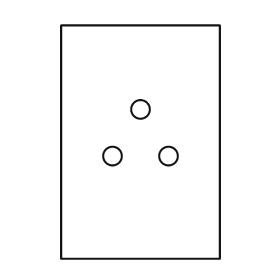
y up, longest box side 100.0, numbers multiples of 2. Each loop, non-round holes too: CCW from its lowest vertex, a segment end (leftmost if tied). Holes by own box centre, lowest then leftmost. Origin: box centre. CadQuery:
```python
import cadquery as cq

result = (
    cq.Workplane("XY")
    .moveTo(-34.0, -50.0)
    .lineTo(34.0, -50.0)
    .lineTo(34.0, 50.0)
    .lineTo(-34.0, 50.0)
    .close()
    .moveTo(-12.0, -6.0)
    .circle(4.0)
    .moveTo(12.0, -6.0)
    .circle(4.0)
    .moveTo(0.0, 14.0)
    .circle(4.0)
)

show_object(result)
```